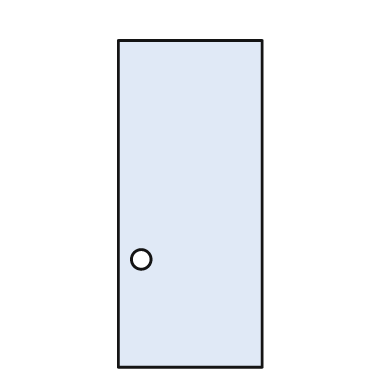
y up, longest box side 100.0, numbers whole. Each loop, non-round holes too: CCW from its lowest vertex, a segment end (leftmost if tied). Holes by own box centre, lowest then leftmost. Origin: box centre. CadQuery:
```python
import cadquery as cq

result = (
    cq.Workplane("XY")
    .moveTo(-22.0, -50.0)
    .lineTo(22.0, -50.0)
    .lineTo(22.0, 50.0)
    .lineTo(-22.0, 50.0)
    .close()
    .moveTo(-15.0, -17.0)
    .circle(3.0)
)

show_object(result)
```